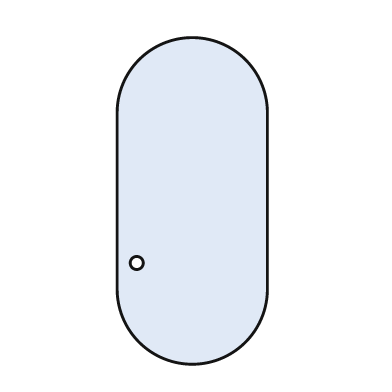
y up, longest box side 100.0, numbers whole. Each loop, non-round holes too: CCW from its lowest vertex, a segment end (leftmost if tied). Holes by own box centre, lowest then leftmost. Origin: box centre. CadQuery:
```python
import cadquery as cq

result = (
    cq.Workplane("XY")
    .moveTo(-23.0, -27.0)
    .threePointArc((0.0, -50.0), (23.0, -27.0))
    .lineTo(23.0, 27.0)
    .threePointArc((0.0, 50.0), (-23.0, 27.0))
    .close()
    .moveTo(-17.0, -19.0)
    .circle(2.0)
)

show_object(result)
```